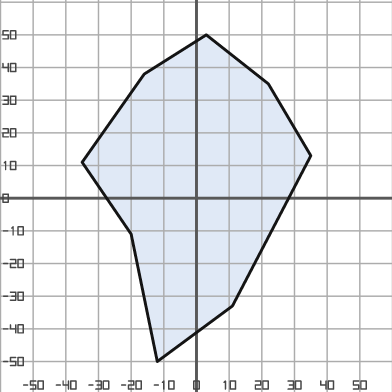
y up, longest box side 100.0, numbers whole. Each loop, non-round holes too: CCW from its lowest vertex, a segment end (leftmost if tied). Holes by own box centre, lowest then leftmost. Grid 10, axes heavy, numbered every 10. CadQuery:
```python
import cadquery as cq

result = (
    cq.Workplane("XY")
    .moveTo(-12.0, -50.0)
    .lineTo(11.0, -33.0)
    .lineTo(35.0, 13.0)
    .lineTo(22.0, 35.0)
    .lineTo(3.0, 50.0)
    .lineTo(-16.0, 38.0)
    .lineTo(-35.0, 11.0)
    .lineTo(-20.0, -11.0)
    .close()
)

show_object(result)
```